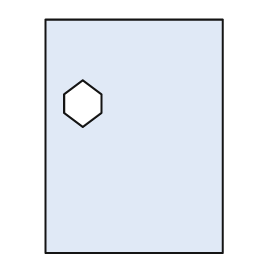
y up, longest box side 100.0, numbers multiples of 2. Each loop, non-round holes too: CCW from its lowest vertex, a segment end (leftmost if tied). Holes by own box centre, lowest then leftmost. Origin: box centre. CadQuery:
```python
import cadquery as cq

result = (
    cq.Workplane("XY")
    .moveTo(-38.0, -50.0)
    .lineTo(38.0, -50.0)
    .lineTo(38.0, 50.0)
    .lineTo(-38.0, 50.0)
    .close()
    .moveTo(-22.0, 4.0)
    .lineTo(-14.0, 10.0)
    .lineTo(-14.0, 18.0)
    .lineTo(-22.0, 24.0)
    .lineTo(-30.0, 18.0)
    .lineTo(-30.0, 10.0)
    .close()
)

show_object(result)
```